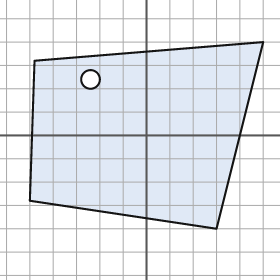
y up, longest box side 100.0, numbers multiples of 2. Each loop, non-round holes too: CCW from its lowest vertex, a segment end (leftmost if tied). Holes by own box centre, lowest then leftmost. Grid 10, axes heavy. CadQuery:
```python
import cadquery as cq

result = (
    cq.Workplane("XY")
    .moveTo(30.0, -40.0)
    .lineTo(50.0, 40.0)
    .lineTo(-48.0, 32.0)
    .lineTo(-50.0, -28.0)
    .close()
    .moveTo(-24.0, 24.0)
    .circle(4.0)
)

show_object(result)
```